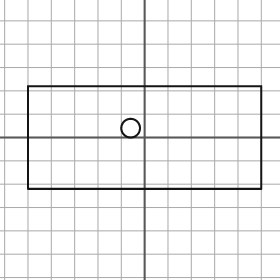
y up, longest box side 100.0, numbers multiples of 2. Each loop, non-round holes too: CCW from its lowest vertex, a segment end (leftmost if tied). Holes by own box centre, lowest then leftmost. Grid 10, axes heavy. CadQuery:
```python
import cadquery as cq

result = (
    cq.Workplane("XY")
    .moveTo(-50.0, -22.0)
    .lineTo(50.0, -22.0)
    .lineTo(50.0, 22.0)
    .lineTo(-50.0, 22.0)
    .close()
    .moveTo(-6.0, 4.0)
    .circle(4.0)
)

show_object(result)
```